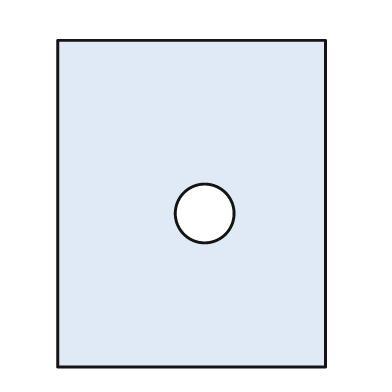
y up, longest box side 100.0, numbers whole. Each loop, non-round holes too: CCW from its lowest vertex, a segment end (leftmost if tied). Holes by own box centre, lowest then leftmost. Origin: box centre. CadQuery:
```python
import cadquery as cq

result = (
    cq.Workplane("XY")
    .moveTo(-41.0, -50.0)
    .lineTo(41.0, -50.0)
    .lineTo(41.0, 50.0)
    .lineTo(-41.0, 50.0)
    .close()
    .moveTo(4.0, -3.0)
    .circle(9.0)
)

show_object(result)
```